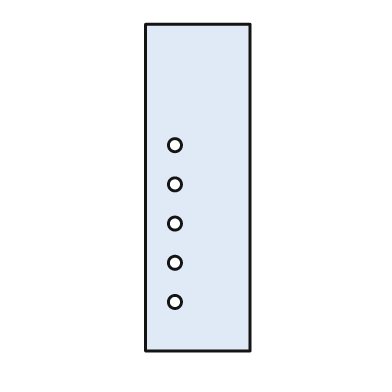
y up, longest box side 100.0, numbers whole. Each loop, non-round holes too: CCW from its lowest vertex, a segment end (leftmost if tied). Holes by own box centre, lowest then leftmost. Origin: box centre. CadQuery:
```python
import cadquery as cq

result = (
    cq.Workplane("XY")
    .moveTo(-16.0, -50.0)
    .lineTo(16.0, -50.0)
    .lineTo(16.0, 50.0)
    .lineTo(-16.0, 50.0)
    .close()
    .moveTo(-7.0, -35.0)
    .circle(2.0)
    .moveTo(-7.0, -23.0)
    .circle(2.0)
    .moveTo(-7.0, -11.0)
    .circle(2.0)
    .moveTo(-7.0, 1.0)
    .circle(2.0)
    .moveTo(-7.0, 13.0)
    .circle(2.0)
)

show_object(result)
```